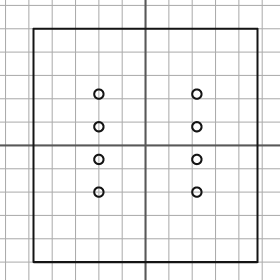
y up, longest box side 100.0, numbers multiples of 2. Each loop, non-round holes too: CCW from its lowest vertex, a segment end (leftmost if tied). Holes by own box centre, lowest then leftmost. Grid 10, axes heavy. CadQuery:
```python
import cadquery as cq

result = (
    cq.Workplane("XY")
    .moveTo(-48.0, -50.0)
    .lineTo(48.0, -50.0)
    .lineTo(48.0, 50.0)
    .lineTo(-48.0, 50.0)
    .close()
    .moveTo(-20.0, -20.0)
    .circle(2.0)
    .moveTo(22.0, -20.0)
    .circle(2.0)
    .moveTo(-20.0, -6.0)
    .circle(2.0)
    .moveTo(22.0, -6.0)
    .circle(2.0)
    .moveTo(-20.0, 8.0)
    .circle(2.0)
    .moveTo(22.0, 8.0)
    .circle(2.0)
    .moveTo(-20.0, 22.0)
    .circle(2.0)
    .moveTo(22.0, 22.0)
    .circle(2.0)
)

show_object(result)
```